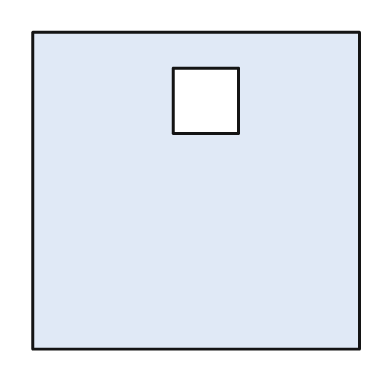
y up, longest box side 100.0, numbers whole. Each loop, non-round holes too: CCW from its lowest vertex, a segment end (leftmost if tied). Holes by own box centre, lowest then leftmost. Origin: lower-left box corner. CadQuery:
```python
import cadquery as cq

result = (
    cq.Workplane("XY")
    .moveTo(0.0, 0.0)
    .lineTo(100.0, 0.0)
    .lineTo(100.0, 97.0)
    .lineTo(0.0, 97.0)
    .close()
    .moveTo(43.0, 66.0)
    .lineTo(63.0, 66.0)
    .lineTo(63.0, 86.0)
    .lineTo(43.0, 86.0)
    .close()
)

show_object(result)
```